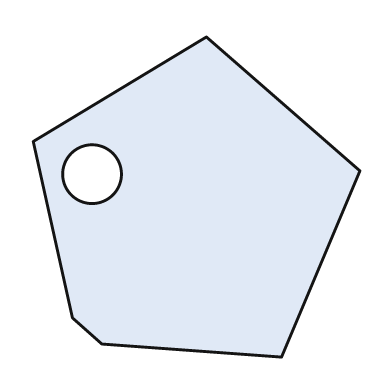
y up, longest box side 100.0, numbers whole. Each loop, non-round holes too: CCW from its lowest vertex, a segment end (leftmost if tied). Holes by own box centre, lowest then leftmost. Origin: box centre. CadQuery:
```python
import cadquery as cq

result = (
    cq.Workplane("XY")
    .moveTo(26.0, -49.0)
    .lineTo(50.0, 8.0)
    .lineTo(3.0, 49.0)
    .lineTo(-50.0, 17.0)
    .lineTo(-38.0, -37.0)
    .lineTo(-29.0, -45.0)
    .close()
    .moveTo(-32.0, 7.0)
    .circle(9.0)
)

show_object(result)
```